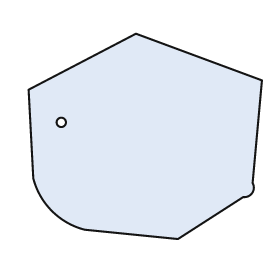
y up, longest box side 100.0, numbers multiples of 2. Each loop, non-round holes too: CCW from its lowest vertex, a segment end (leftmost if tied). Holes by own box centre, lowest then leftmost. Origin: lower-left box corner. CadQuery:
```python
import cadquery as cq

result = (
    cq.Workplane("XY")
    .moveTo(64.0, 0.0)
    .lineTo(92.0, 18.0)
    .threePointArc((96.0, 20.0), (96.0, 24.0))
    .lineTo(100.0, 68.0)
    .lineTo(46.0, 88.0)
    .lineTo(0.0, 64.0)
    .lineTo(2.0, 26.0)
    .threePointArc((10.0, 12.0), (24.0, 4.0))
    .close()
    .moveTo(14.0, 50.0)
    .circle(2.0)
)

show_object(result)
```